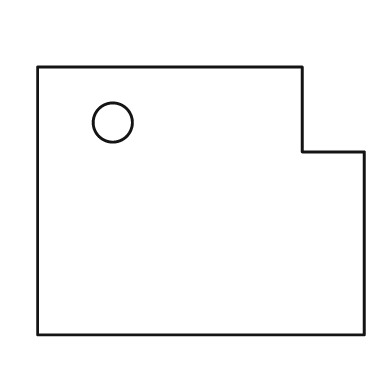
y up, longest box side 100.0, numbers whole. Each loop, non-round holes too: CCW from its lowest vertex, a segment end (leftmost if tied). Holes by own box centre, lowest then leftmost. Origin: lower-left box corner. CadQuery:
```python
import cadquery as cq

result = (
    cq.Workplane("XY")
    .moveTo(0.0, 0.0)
    .lineTo(100.0, 0.0)
    .lineTo(100.0, 56.0)
    .lineTo(81.0, 56.0)
    .lineTo(81.0, 82.0)
    .lineTo(0.0, 82.0)
    .close()
    .moveTo(23.0, 65.0)
    .circle(6.0)
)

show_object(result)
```